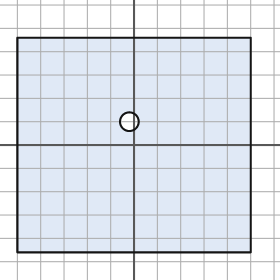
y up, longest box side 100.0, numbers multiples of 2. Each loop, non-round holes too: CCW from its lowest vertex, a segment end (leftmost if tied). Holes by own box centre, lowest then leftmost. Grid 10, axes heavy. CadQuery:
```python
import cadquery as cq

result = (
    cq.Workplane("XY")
    .moveTo(-50.0, -46.0)
    .lineTo(50.0, -46.0)
    .lineTo(50.0, 46.0)
    .lineTo(-50.0, 46.0)
    .close()
    .moveTo(-2.0, 10.0)
    .circle(4.0)
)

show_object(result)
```